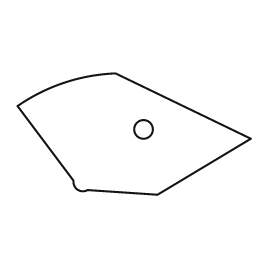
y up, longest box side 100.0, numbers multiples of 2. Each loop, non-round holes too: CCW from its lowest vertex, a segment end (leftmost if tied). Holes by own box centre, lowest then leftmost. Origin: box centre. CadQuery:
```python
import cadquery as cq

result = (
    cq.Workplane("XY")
    .moveTo(10.0, -26.0)
    .lineTo(50.0, -2.0)
    .lineTo(-8.0, 26.0)
    .threePointArc((-30.0, 22.0), (-50.0, 12.0))
    .lineTo(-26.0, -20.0)
    .threePointArc((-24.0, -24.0), (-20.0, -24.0))
    .close()
    .moveTo(4.0, 2.0)
    .circle(4.0)
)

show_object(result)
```